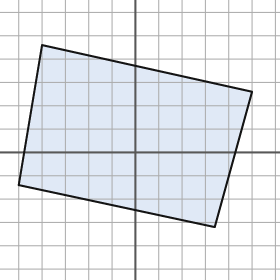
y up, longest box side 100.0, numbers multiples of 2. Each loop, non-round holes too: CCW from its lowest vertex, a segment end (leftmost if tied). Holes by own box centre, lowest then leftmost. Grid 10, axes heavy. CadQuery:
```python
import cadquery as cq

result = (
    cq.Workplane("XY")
    .moveTo(34.0, -32.0)
    .lineTo(50.0, 26.0)
    .lineTo(-40.0, 46.0)
    .lineTo(-50.0, -14.0)
    .close()
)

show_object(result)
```